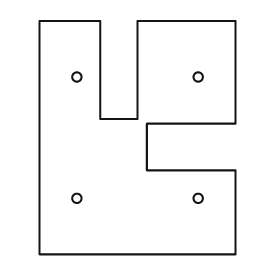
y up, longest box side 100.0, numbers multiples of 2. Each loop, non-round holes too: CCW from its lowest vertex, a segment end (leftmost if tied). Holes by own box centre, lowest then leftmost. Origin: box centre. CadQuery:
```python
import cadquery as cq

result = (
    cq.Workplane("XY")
    .moveTo(-42.0, -50.0)
    .lineTo(42.0, -50.0)
    .lineTo(42.0, -14.0)
    .lineTo(4.0, -14.0)
    .lineTo(4.0, 6.0)
    .lineTo(42.0, 6.0)
    .lineTo(42.0, 50.0)
    .lineTo(0.0, 50.0)
    .lineTo(0.0, 8.0)
    .lineTo(-16.0, 8.0)
    .lineTo(-16.0, 50.0)
    .lineTo(-42.0, 50.0)
    .close()
    .moveTo(-26.0, -26.0)
    .circle(2.0)
    .moveTo(26.0, -26.0)
    .circle(2.0)
    .moveTo(-26.0, 26.0)
    .circle(2.0)
    .moveTo(26.0, 26.0)
    .circle(2.0)
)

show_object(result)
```